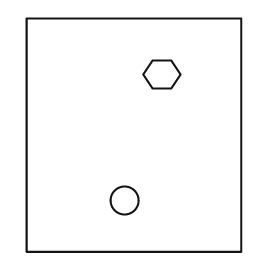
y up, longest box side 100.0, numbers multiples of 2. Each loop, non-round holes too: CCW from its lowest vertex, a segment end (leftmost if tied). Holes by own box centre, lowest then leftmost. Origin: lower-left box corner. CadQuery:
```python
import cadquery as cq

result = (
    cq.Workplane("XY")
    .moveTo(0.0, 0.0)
    .lineTo(92.0, 0.0)
    .lineTo(92.0, 100.0)
    .lineTo(0.0, 100.0)
    .close()
    .moveTo(42.0, 22.0)
    .circle(6.0)
    .moveTo(54.0, 70.0)
    .lineTo(62.0, 70.0)
    .lineTo(66.0, 76.0)
    .lineTo(62.0, 82.0)
    .lineTo(54.0, 82.0)
    .lineTo(50.0, 76.0)
    .close()
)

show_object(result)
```